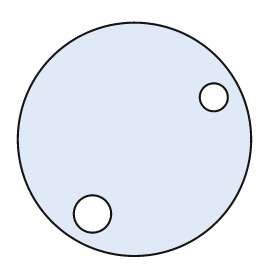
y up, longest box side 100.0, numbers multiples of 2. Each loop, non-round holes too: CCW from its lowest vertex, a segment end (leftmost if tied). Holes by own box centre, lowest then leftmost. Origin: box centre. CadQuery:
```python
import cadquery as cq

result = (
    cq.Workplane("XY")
    .moveTo(0.0, 0.0)
    .circle(50.0)
    .moveTo(-18.0, -32.0)
    .circle(8.0)
    .moveTo(34.0, 18.0)
    .circle(6.0)
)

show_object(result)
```